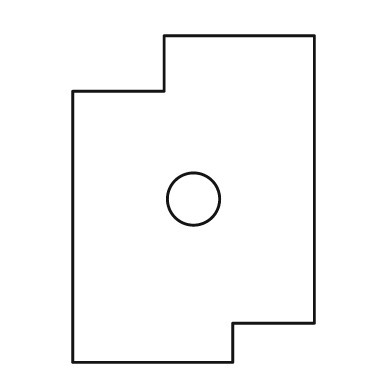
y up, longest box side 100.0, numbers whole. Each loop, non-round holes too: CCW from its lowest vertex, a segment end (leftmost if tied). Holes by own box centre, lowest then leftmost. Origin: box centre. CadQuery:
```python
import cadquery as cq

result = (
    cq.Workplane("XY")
    .moveTo(-37.0, -50.0)
    .lineTo(12.0, -50.0)
    .lineTo(12.0, -38.0)
    .lineTo(37.0, -38.0)
    .lineTo(37.0, 50.0)
    .lineTo(-9.0, 50.0)
    .lineTo(-9.0, 33.0)
    .lineTo(-37.0, 33.0)
    .close()
    .moveTo(0.0, 0.0)
    .circle(8.0)
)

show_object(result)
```